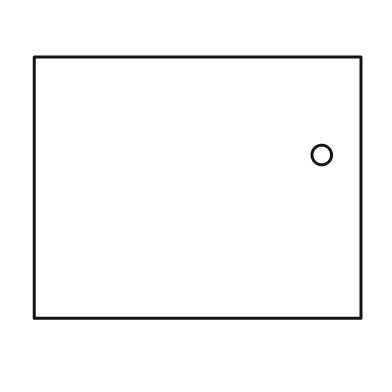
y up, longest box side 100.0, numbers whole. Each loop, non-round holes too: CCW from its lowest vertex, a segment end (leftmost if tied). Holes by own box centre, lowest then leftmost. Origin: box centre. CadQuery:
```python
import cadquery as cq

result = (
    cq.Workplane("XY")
    .moveTo(-50.0, -40.0)
    .lineTo(50.0, -40.0)
    .lineTo(50.0, 40.0)
    .lineTo(-50.0, 40.0)
    .close()
    .moveTo(38.0, 10.0)
    .circle(3.0)
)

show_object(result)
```